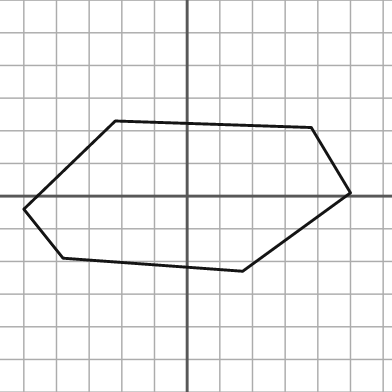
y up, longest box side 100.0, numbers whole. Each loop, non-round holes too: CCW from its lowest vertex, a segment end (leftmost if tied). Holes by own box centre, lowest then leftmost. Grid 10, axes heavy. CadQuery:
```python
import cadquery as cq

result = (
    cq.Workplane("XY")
    .moveTo(17.0, -23.0)
    .lineTo(50.0, 1.0)
    .lineTo(38.0, 21.0)
    .lineTo(-22.0, 23.0)
    .lineTo(-50.0, -4.0)
    .lineTo(-38.0, -19.0)
    .close()
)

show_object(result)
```